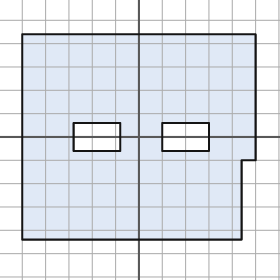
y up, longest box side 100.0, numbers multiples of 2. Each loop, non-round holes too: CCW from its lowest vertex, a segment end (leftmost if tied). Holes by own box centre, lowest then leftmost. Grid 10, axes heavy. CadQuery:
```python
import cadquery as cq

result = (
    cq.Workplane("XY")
    .moveTo(-50.0, -44.0)
    .lineTo(44.0, -44.0)
    .lineTo(44.0, -10.0)
    .lineTo(50.0, -10.0)
    .lineTo(50.0, 44.0)
    .lineTo(-50.0, 44.0)
    .close()
    .moveTo(-28.0, -6.0)
    .lineTo(-8.0, -6.0)
    .lineTo(-8.0, 6.0)
    .lineTo(-28.0, 6.0)
    .close()
    .moveTo(10.0, -6.0)
    .lineTo(30.0, -6.0)
    .lineTo(30.0, 6.0)
    .lineTo(10.0, 6.0)
    .close()
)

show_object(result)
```